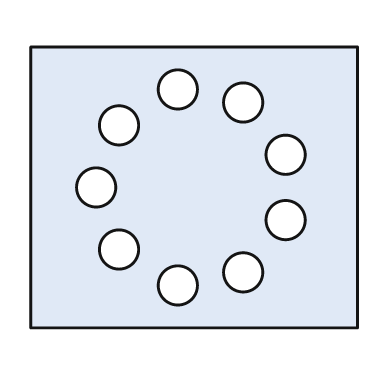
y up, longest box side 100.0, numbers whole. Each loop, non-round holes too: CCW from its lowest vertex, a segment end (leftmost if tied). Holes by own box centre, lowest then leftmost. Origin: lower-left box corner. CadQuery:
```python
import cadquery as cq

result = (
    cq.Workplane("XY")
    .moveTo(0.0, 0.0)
    .lineTo(100.0, 0.0)
    .lineTo(100.0, 86.0)
    .lineTo(0.0, 86.0)
    .close()
    .moveTo(45.0, 13.0)
    .circle(6.0)
    .moveTo(65.0, 17.0)
    .circle(6.0)
    .moveTo(27.0, 24.0)
    .circle(6.0)
    .moveTo(78.0, 33.0)
    .circle(6.0)
    .moveTo(20.0, 43.0)
    .circle(6.0)
    .moveTo(78.0, 53.0)
    .circle(6.0)
    .moveTo(27.0, 62.0)
    .circle(6.0)
    .moveTo(65.0, 69.0)
    .circle(6.0)
    .moveTo(45.0, 73.0)
    .circle(6.0)
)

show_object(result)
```